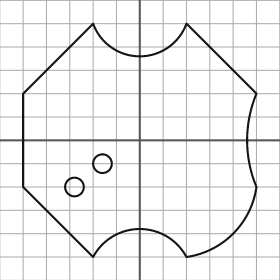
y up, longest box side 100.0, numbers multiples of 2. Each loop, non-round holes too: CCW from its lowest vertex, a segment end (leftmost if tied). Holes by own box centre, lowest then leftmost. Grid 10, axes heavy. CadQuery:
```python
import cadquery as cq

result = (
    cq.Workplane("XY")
    .moveTo(-20.0, -50.0)
    .threePointArc((0.0, -38.0), (20.0, -50.0))
    .threePointArc((40.0, -40.0), (50.0, -20.0))
    .threePointArc((46.0, 0.0), (50.0, 20.0))
    .lineTo(20.0, 50.0)
    .threePointArc((0.0, 36.0), (-20.0, 50.0))
    .lineTo(-50.0, 20.0)
    .lineTo(-50.0, -20.0)
    .close()
    .moveTo(-28.0, -20.0)
    .circle(4.0)
    .moveTo(-16.0, -10.0)
    .circle(4.0)
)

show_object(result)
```